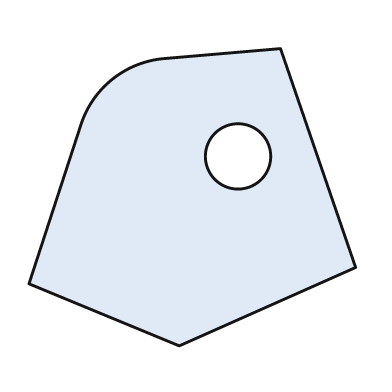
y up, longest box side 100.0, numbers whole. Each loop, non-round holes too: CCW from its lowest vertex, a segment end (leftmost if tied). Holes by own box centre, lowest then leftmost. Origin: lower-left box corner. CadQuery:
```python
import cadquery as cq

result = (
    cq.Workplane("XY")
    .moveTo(46.0, 0.0)
    .lineTo(100.0, 24.0)
    .lineTo(77.0, 91.0)
    .lineTo(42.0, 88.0)
    .threePointArc((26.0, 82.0), (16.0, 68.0))
    .lineTo(0.0, 19.0)
    .close()
    .moveTo(64.0, 58.0)
    .circle(10.0)
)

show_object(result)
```